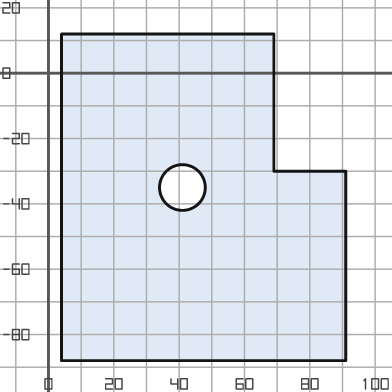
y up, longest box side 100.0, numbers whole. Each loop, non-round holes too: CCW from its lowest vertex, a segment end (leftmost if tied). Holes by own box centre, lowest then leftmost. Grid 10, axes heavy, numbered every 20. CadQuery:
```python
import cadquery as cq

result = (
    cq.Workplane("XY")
    .moveTo(4.0, -88.0)
    .lineTo(91.0, -88.0)
    .lineTo(91.0, -30.0)
    .lineTo(69.0, -30.0)
    .lineTo(69.0, 12.0)
    .lineTo(4.0, 12.0)
    .close()
    .moveTo(41.0, -35.0)
    .circle(7.0)
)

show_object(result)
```